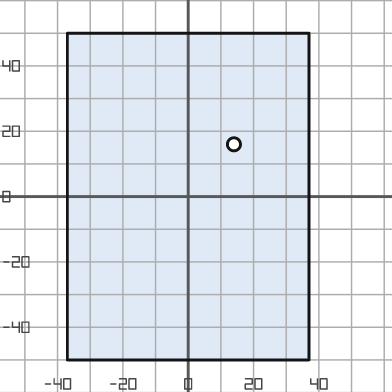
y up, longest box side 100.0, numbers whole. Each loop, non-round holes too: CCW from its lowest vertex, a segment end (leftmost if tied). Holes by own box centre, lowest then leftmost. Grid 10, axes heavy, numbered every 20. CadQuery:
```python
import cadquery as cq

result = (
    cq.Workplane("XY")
    .moveTo(-37.0, -50.0)
    .lineTo(37.0, -50.0)
    .lineTo(37.0, 50.0)
    .lineTo(-37.0, 50.0)
    .close()
    .moveTo(14.0, 16.0)
    .circle(2.0)
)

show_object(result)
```